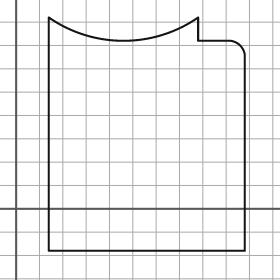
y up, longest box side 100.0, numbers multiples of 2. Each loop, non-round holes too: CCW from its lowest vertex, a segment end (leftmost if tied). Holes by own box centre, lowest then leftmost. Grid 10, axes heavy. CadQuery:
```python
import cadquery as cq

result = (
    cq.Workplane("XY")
    .moveTo(14.0, -18.0)
    .lineTo(98.0, -18.0)
    .lineTo(98.0, 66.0)
    .threePointArc((96.0, 70.0), (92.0, 72.0))
    .lineTo(78.0, 72.0)
    .lineTo(78.0, 82.0)
    .threePointArc((46.0, 72.0), (14.0, 82.0))
    .close()
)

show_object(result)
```